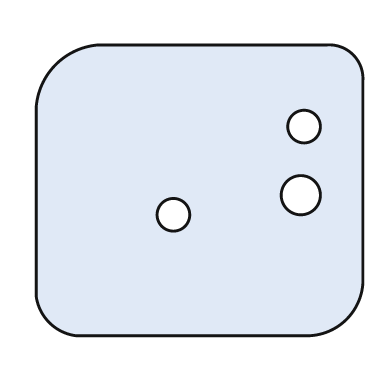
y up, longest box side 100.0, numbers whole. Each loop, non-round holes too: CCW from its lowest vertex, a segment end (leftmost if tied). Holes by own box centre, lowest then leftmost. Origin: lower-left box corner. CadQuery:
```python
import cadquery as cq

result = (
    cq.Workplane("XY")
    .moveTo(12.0, 0.0)
    .lineTo(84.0, 0.0)
    .threePointArc((95.0, 5.0), (100.0, 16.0))
    .lineTo(100.0, 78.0)
    .threePointArc((97.0, 86.0), (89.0, 89.0))
    .lineTo(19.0, 89.0)
    .threePointArc((6.0, 83.0), (0.0, 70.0))
    .lineTo(0.0, 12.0)
    .threePointArc((4.0, 4.0), (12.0, 0.0))
    .close()
    .moveTo(42.0, 37.0)
    .circle(5.0)
    .moveTo(81.0, 43.0)
    .circle(6.0)
    .moveTo(82.0, 64.0)
    .circle(5.0)
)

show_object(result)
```